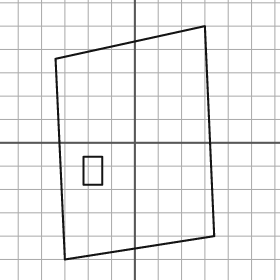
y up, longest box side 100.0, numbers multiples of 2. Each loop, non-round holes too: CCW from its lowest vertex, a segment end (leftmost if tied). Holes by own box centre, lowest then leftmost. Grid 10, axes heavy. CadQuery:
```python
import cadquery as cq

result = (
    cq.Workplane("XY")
    .moveTo(-30.0, -50.0)
    .lineTo(34.0, -40.0)
    .lineTo(30.0, 50.0)
    .lineTo(-34.0, 36.0)
    .close()
    .moveTo(-22.0, -18.0)
    .lineTo(-14.0, -18.0)
    .lineTo(-14.0, -6.0)
    .lineTo(-22.0, -6.0)
    .close()
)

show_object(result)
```